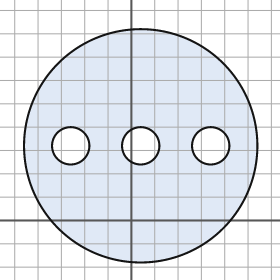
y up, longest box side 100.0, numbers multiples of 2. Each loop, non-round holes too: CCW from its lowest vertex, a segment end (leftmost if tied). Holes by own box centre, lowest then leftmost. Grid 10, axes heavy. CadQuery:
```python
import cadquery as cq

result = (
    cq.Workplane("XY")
    .moveTo(4.0, 32.0)
    .circle(50.0)
    .moveTo(-26.0, 32.0)
    .circle(8.0)
    .moveTo(4.0, 32.0)
    .circle(8.0)
    .moveTo(34.0, 32.0)
    .circle(8.0)
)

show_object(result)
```